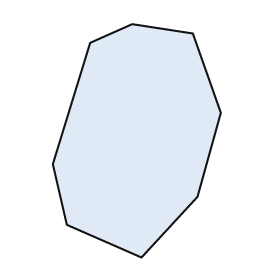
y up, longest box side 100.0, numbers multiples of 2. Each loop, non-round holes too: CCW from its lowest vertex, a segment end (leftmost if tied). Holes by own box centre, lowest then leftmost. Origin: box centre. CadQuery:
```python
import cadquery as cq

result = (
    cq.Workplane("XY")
    .moveTo(2.0, -50.0)
    .lineTo(26.0, -24.0)
    .lineTo(36.0, 12.0)
    .lineTo(24.0, 46.0)
    .lineTo(-2.0, 50.0)
    .lineTo(-20.0, 42.0)
    .lineTo(-36.0, -10.0)
    .lineTo(-30.0, -36.0)
    .close()
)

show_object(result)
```